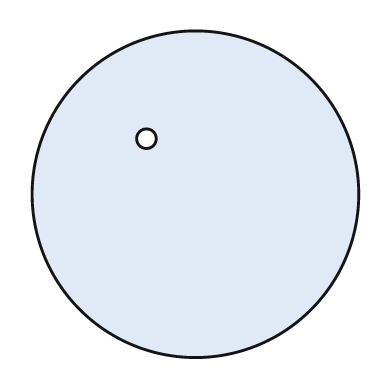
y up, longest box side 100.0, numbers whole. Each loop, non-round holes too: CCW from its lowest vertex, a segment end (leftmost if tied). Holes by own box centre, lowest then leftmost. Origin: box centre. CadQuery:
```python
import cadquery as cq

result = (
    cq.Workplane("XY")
    .moveTo(0.0, 0.0)
    .circle(50.0)
    .moveTo(-15.0, 17.0)
    .circle(3.0)
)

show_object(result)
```